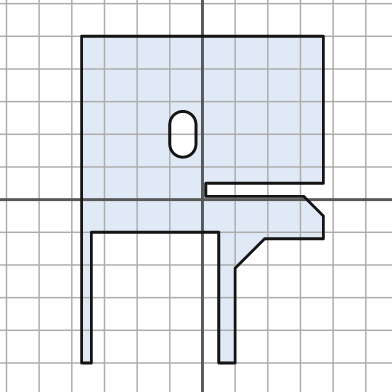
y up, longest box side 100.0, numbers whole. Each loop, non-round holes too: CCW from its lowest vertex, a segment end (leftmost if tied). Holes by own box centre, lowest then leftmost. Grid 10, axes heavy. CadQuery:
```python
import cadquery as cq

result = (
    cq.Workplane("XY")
    .moveTo(-37.0, -50.0)
    .lineTo(-34.0, -50.0)
    .lineTo(-34.0, -10.0)
    .lineTo(5.0, -10.0)
    .lineTo(5.0, -50.0)
    .lineTo(10.0, -50.0)
    .lineTo(10.0, -21.0)
    .lineTo(19.0, -12.0)
    .lineTo(37.0, -12.0)
    .lineTo(37.0, -5.0)
    .lineTo(31.0, 1.0)
    .lineTo(1.0, 1.0)
    .lineTo(1.0, 5.0)
    .lineTo(37.0, 5.0)
    .lineTo(37.0, 50.0)
    .lineTo(-37.0, 50.0)
    .close()
    .moveTo(-10.0, 17.0)
    .threePointArc((-6.0, 13.0), (-2.0, 17.0))
    .lineTo(-2.0, 23.0)
    .threePointArc((-6.0, 27.0), (-10.0, 23.0))
    .close()
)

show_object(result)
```